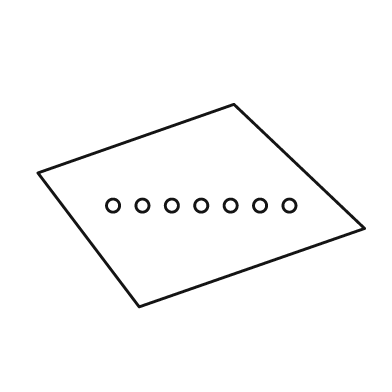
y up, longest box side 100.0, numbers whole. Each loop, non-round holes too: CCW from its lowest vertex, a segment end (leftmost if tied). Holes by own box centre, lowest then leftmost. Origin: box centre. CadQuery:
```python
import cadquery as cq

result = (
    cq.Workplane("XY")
    .moveTo(-19.0, -31.0)
    .lineTo(50.0, -7.0)
    .lineTo(10.0, 31.0)
    .lineTo(-50.0, 10.0)
    .close()
    .moveTo(-27.0, 0.0)
    .circle(2.0)
    .moveTo(-18.0, 0.0)
    .circle(2.0)
    .moveTo(-9.0, 0.0)
    .circle(2.0)
    .moveTo(0.0, 0.0)
    .circle(2.0)
    .moveTo(9.0, 0.0)
    .circle(2.0)
    .moveTo(18.0, 0.0)
    .circle(2.0)
    .moveTo(27.0, 0.0)
    .circle(2.0)
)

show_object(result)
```